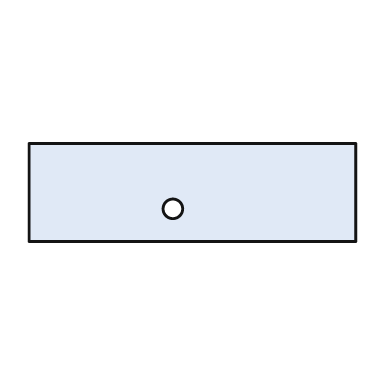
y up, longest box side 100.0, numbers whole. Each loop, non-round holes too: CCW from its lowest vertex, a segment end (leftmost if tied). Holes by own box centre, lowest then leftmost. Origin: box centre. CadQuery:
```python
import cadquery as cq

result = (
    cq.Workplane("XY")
    .moveTo(-50.0, -15.0)
    .lineTo(50.0, -15.0)
    .lineTo(50.0, 15.0)
    .lineTo(-50.0, 15.0)
    .close()
    .moveTo(-6.0, -5.0)
    .circle(3.0)
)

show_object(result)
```